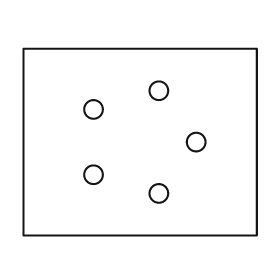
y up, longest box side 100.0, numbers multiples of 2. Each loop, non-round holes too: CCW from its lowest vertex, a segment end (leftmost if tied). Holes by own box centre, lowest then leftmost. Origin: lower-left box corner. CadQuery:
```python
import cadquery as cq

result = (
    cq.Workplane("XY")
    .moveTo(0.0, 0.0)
    .lineTo(100.0, 0.0)
    .lineTo(100.0, 80.0)
    .lineTo(0.0, 80.0)
    .close()
    .moveTo(58.0, 18.0)
    .circle(4.0)
    .moveTo(30.0, 26.0)
    .circle(4.0)
    .moveTo(74.0, 40.0)
    .circle(4.0)
    .moveTo(30.0, 54.0)
    .circle(4.0)
    .moveTo(58.0, 62.0)
    .circle(4.0)
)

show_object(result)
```